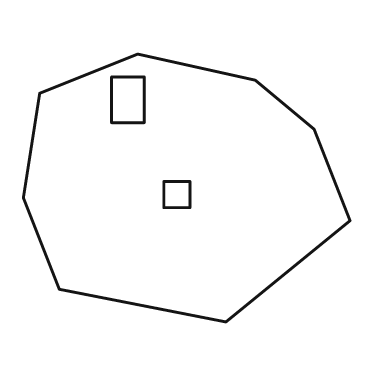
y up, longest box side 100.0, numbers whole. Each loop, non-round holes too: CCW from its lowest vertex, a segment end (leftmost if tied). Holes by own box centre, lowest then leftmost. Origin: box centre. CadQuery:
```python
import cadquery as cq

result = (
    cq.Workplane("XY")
    .moveTo(12.0, -41.0)
    .lineTo(50.0, -10.0)
    .lineTo(39.0, 18.0)
    .lineTo(21.0, 33.0)
    .lineTo(-15.0, 41.0)
    .lineTo(-45.0, 29.0)
    .lineTo(-50.0, -3.0)
    .lineTo(-39.0, -31.0)
    .close()
    .moveTo(-7.0, -6.0)
    .lineTo(1.0, -6.0)
    .lineTo(1.0, 2.0)
    .lineTo(-7.0, 2.0)
    .close()
    .moveTo(-23.0, 20.0)
    .lineTo(-13.0, 20.0)
    .lineTo(-13.0, 34.0)
    .lineTo(-23.0, 34.0)
    .close()
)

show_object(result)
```